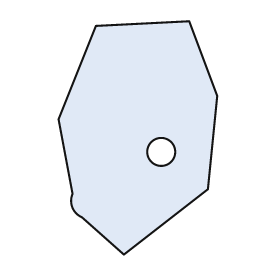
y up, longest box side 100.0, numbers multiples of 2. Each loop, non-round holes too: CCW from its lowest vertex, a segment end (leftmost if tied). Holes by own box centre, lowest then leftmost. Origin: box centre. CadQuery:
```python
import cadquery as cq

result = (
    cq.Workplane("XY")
    .moveTo(-6.0, -50.0)
    .lineTo(30.0, -22.0)
    .lineTo(34.0, 18.0)
    .lineTo(22.0, 50.0)
    .lineTo(-18.0, 48.0)
    .lineTo(-34.0, 8.0)
    .lineTo(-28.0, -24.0)
    .threePointArc((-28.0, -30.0), (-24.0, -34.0))
    .close()
    .moveTo(10.0, -6.0)
    .circle(6.0)
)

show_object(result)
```